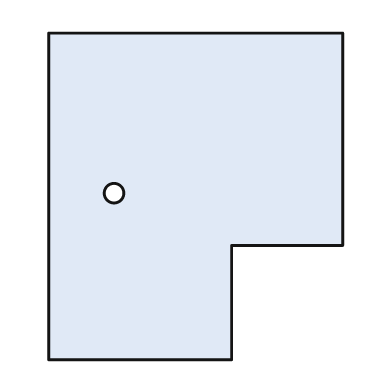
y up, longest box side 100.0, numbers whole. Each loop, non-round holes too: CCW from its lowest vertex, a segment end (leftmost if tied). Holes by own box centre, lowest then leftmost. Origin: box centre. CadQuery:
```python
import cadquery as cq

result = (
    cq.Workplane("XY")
    .moveTo(-45.0, -50.0)
    .lineTo(11.0, -50.0)
    .lineTo(11.0, -15.0)
    .lineTo(45.0, -15.0)
    .lineTo(45.0, 50.0)
    .lineTo(-45.0, 50.0)
    .close()
    .moveTo(-25.0, 1.0)
    .circle(3.0)
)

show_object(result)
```